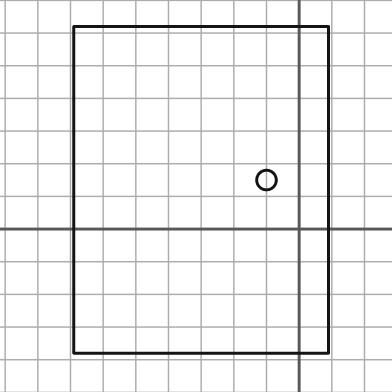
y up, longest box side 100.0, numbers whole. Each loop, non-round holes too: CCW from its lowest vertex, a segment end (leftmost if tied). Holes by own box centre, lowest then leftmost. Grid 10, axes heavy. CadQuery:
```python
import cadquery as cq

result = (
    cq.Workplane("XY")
    .moveTo(-69.0, -38.0)
    .lineTo(9.0, -38.0)
    .lineTo(9.0, 62.0)
    .lineTo(-69.0, 62.0)
    .close()
    .moveTo(-10.0, 15.0)
    .circle(3.0)
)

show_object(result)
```